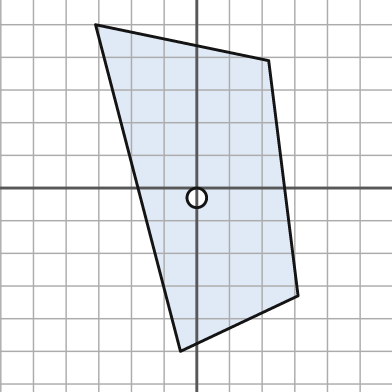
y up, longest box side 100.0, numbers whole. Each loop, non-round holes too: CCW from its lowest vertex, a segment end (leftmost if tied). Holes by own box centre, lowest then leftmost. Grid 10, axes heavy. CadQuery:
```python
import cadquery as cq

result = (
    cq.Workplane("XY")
    .moveTo(-5.0, -50.0)
    .lineTo(31.0, -33.0)
    .lineTo(22.0, 39.0)
    .lineTo(-31.0, 50.0)
    .close()
    .moveTo(0.0, -3.0)
    .circle(3.0)
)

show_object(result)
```